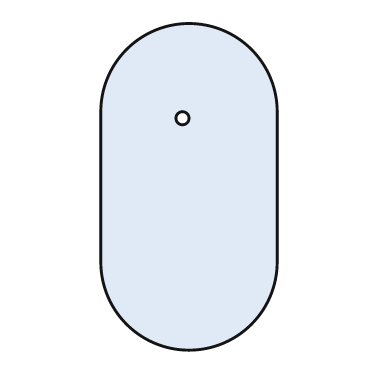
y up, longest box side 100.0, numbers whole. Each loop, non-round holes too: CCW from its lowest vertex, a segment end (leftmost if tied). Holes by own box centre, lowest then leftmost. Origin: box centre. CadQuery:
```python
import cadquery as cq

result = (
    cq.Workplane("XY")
    .moveTo(-27.0, -23.0)
    .threePointArc((0.0, -50.0), (27.0, -23.0))
    .lineTo(27.0, 23.0)
    .threePointArc((0.0, 50.0), (-27.0, 23.0))
    .close()
    .moveTo(-2.0, 21.0)
    .circle(2.0)
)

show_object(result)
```